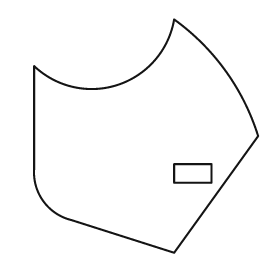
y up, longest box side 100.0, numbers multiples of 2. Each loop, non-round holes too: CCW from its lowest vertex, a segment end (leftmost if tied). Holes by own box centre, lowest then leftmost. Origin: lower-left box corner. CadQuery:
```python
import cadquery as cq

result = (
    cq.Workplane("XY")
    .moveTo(60.0, 0.0)
    .lineTo(96.0, 50.0)
    .threePointArc((82.0, 78.0), (60.0, 100.0))
    .threePointArc((36.0, 72.0), (0.0, 80.0))
    .lineTo(0.0, 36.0)
    .threePointArc((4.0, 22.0), (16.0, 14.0))
    .close()
    .moveTo(60.0, 30.0)
    .lineTo(76.0, 30.0)
    .lineTo(76.0, 38.0)
    .lineTo(60.0, 38.0)
    .close()
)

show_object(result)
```